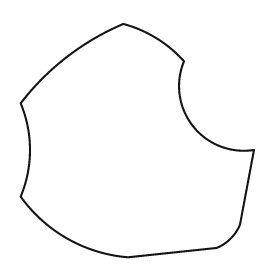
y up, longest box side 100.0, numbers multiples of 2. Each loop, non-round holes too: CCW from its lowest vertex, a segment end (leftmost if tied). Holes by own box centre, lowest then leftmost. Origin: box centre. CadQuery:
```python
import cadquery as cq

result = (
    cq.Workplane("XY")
    .moveTo(-4.0, -50.0)
    .lineTo(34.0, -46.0)
    .threePointArc((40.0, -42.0), (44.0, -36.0))
    .lineTo(50.0, -4.0)
    .threePointArc((24.0, 6.0), (20.0, 34.0))
    .threePointArc((8.0, 44.0), (-6.0, 50.0))
    .threePointArc((-30.0, 36.0), (-50.0, 16.0))
    .threePointArc((-46.0, -4.0), (-50.0, -24.0))
    .threePointArc((-30.0, -42.0), (-4.0, -50.0))
    .close()
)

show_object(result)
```